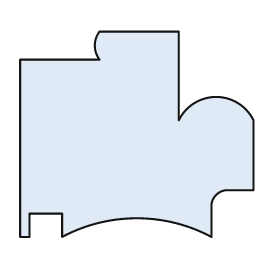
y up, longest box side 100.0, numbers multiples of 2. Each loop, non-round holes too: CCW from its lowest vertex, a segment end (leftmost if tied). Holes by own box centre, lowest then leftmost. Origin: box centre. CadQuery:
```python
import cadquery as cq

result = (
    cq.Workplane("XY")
    .moveTo(-50.0, -44.0)
    .lineTo(-46.0, -44.0)
    .lineTo(-46.0, -34.0)
    .lineTo(-32.0, -34.0)
    .lineTo(-32.0, -44.0)
    .threePointArc((0.0, -36.0), (32.0, -44.0))
    .lineTo(32.0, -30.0)
    .threePointArc((34.0, -26.0), (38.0, -24.0))
    .lineTo(50.0, -24.0)
    .lineTo(50.0, 6.0)
    .threePointArc((34.0, 16.0), (18.0, 6.0))
    .lineTo(18.0, 44.0)
    .lineTo(-16.0, 44.0)
    .threePointArc((-18.0, 38.0), (-16.0, 32.0))
    .lineTo(-50.0, 32.0)
    .close()
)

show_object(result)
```